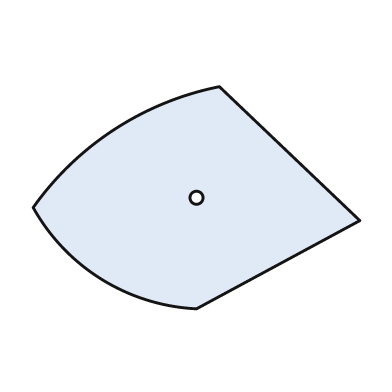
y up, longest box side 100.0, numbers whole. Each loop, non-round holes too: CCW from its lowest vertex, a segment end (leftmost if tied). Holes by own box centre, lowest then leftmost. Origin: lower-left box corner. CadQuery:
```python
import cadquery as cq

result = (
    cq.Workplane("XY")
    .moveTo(50.0, 0.0)
    .lineTo(100.0, 27.0)
    .lineTo(57.0, 68.0)
    .threePointArc((25.0, 55.0), (0.0, 31.0))
    .threePointArc((21.0, 9.0), (50.0, 0.0))
    .close()
    .moveTo(50.0, 34.0)
    .circle(2.0)
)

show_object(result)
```